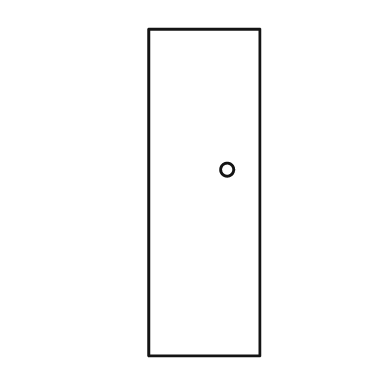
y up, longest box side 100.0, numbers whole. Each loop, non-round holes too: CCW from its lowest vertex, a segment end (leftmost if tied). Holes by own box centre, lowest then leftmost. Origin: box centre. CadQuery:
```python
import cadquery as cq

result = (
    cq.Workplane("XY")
    .moveTo(-17.0, -50.0)
    .lineTo(17.0, -50.0)
    .lineTo(17.0, 50.0)
    .lineTo(-17.0, 50.0)
    .close()
    .moveTo(7.0, 7.0)
    .circle(2.0)
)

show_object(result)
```